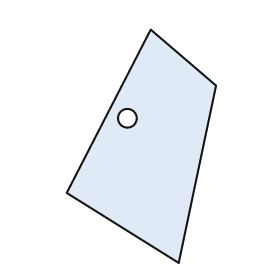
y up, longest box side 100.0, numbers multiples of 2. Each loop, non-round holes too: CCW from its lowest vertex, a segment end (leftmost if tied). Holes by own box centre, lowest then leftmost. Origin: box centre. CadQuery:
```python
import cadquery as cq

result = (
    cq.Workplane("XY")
    .moveTo(16.0, -50.0)
    .lineTo(32.0, 26.0)
    .lineTo(4.0, 50.0)
    .lineTo(-32.0, -20.0)
    .close()
    .moveTo(-6.0, 12.0)
    .circle(4.0)
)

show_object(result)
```